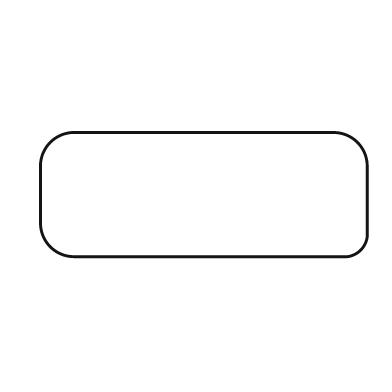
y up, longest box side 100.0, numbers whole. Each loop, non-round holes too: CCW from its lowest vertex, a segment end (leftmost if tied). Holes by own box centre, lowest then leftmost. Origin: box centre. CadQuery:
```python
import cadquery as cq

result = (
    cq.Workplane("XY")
    .moveTo(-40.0, -19.0)
    .lineTo(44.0, -19.0)
    .threePointArc((48.0, -17.0), (50.0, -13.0))
    .lineTo(50.0, 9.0)
    .threePointArc((47.0, 16.0), (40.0, 19.0))
    .lineTo(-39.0, 19.0)
    .threePointArc((-47.0, 16.0), (-50.0, 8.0))
    .lineTo(-50.0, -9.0)
    .threePointArc((-47.0, -16.0), (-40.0, -19.0))
    .close()
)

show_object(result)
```